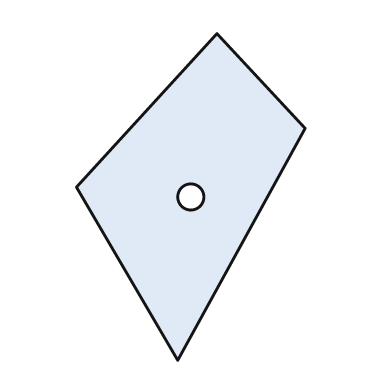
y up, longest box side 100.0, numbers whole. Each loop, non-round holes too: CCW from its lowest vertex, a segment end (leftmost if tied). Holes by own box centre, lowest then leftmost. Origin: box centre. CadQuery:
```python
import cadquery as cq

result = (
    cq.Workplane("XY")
    .moveTo(-4.0, -50.0)
    .lineTo(35.0, 21.0)
    .lineTo(8.0, 50.0)
    .lineTo(-35.0, 3.0)
    .close()
    .moveTo(0.0, 0.0)
    .circle(4.0)
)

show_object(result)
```